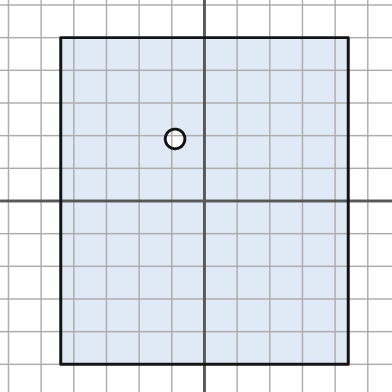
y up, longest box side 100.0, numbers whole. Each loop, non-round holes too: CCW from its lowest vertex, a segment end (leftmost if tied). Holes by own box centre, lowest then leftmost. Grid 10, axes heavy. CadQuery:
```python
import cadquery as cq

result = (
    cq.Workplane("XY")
    .moveTo(-44.0, -50.0)
    .lineTo(44.0, -50.0)
    .lineTo(44.0, 50.0)
    .lineTo(-44.0, 50.0)
    .close()
    .moveTo(-9.0, 19.0)
    .circle(3.0)
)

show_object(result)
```